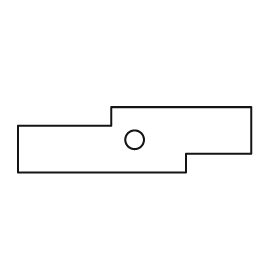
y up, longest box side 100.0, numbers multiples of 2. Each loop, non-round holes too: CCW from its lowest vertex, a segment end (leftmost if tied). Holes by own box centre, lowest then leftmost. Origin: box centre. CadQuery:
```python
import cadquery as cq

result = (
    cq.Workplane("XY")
    .moveTo(-50.0, -14.0)
    .lineTo(22.0, -14.0)
    .lineTo(22.0, -6.0)
    .lineTo(50.0, -6.0)
    .lineTo(50.0, 14.0)
    .lineTo(-10.0, 14.0)
    .lineTo(-10.0, 6.0)
    .lineTo(-50.0, 6.0)
    .close()
    .moveTo(0.0, 0.0)
    .circle(4.0)
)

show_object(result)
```